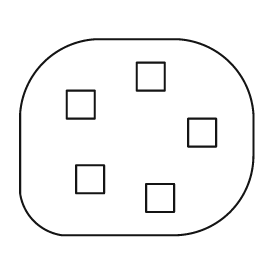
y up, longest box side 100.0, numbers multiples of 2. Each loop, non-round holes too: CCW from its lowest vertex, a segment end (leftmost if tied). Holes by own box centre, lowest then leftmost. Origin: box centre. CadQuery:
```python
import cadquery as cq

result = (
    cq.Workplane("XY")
    .moveTo(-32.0, -42.0)
    .lineTo(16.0, -42.0)
    .threePointArc((40.0, -32.0), (50.0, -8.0))
    .lineTo(50.0, 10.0)
    .threePointArc((40.0, 32.0), (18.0, 42.0))
    .lineTo(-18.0, 42.0)
    .threePointArc((-40.0, 32.0), (-50.0, 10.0))
    .lineTo(-50.0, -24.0)
    .threePointArc((-44.0, -36.0), (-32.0, -42.0))
    .close()
    .moveTo(4.0, -32.0)
    .lineTo(16.0, -32.0)
    .lineTo(16.0, -20.0)
    .lineTo(4.0, -20.0)
    .close()
    .moveTo(-26.0, -24.0)
    .lineTo(-14.0, -24.0)
    .lineTo(-14.0, -12.0)
    .lineTo(-26.0, -12.0)
    .close()
    .moveTo(22.0, -4.0)
    .lineTo(34.0, -4.0)
    .lineTo(34.0, 8.0)
    .lineTo(22.0, 8.0)
    .close()
    .moveTo(-30.0, 8.0)
    .lineTo(-18.0, 8.0)
    .lineTo(-18.0, 20.0)
    .lineTo(-30.0, 20.0)
    .close()
    .moveTo(0.0, 20.0)
    .lineTo(12.0, 20.0)
    .lineTo(12.0, 32.0)
    .lineTo(0.0, 32.0)
    .close()
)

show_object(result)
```